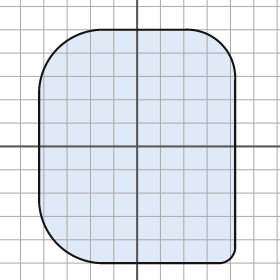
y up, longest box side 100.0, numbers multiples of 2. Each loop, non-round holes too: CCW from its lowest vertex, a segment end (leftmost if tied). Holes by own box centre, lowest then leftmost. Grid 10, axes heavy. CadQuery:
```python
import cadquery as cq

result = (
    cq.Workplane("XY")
    .moveTo(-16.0, -50.0)
    .lineTo(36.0, -50.0)
    .threePointArc((40.0, -48.0), (42.0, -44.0))
    .lineTo(42.0, 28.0)
    .threePointArc((36.0, 44.0), (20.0, 50.0))
    .lineTo(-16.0, 50.0)
    .threePointArc((-34.0, 42.0), (-42.0, 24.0))
    .lineTo(-42.0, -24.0)
    .threePointArc((-34.0, -42.0), (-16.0, -50.0))
    .close()
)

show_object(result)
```